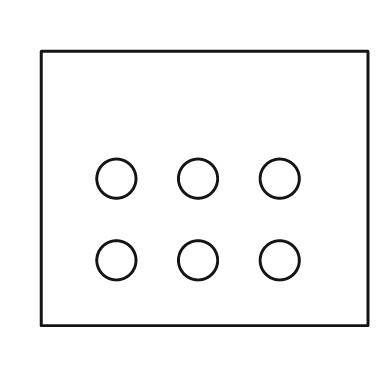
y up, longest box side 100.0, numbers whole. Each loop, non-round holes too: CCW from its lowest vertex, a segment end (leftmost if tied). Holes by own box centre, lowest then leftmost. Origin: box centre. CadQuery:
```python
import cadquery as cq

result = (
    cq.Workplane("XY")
    .moveTo(-50.0, -42.0)
    .lineTo(50.0, -42.0)
    .lineTo(50.0, 42.0)
    .lineTo(-50.0, 42.0)
    .close()
    .moveTo(-27.0, -22.0)
    .circle(6.0)
    .moveTo(-2.0, -22.0)
    .circle(6.0)
    .moveTo(23.0, -22.0)
    .circle(6.0)
    .moveTo(-27.0, 3.0)
    .circle(6.0)
    .moveTo(-2.0, 3.0)
    .circle(6.0)
    .moveTo(23.0, 3.0)
    .circle(6.0)
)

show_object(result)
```